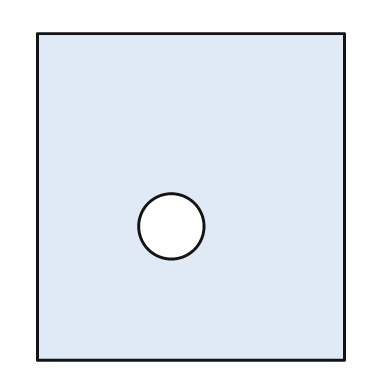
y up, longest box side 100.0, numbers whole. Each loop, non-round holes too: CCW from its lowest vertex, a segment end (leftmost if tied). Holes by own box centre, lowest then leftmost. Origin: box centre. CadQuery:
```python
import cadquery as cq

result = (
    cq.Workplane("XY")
    .moveTo(-47.0, -50.0)
    .lineTo(47.0, -50.0)
    .lineTo(47.0, 50.0)
    .lineTo(-47.0, 50.0)
    .close()
    .moveTo(-6.0, -9.0)
    .circle(10.0)
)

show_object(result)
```